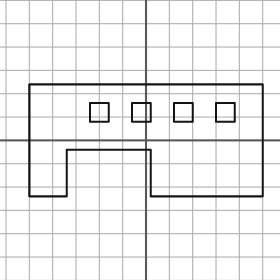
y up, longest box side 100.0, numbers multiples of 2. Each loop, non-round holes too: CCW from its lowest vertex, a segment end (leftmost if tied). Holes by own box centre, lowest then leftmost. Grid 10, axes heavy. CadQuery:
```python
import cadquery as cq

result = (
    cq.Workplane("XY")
    .moveTo(-50.0, -24.0)
    .lineTo(-34.0, -24.0)
    .lineTo(-34.0, -4.0)
    .lineTo(2.0, -4.0)
    .lineTo(2.0, -24.0)
    .lineTo(50.0, -24.0)
    .lineTo(50.0, 24.0)
    .lineTo(-50.0, 24.0)
    .close()
    .moveTo(-24.0, 8.0)
    .lineTo(-16.0, 8.0)
    .lineTo(-16.0, 16.0)
    .lineTo(-24.0, 16.0)
    .close()
    .moveTo(-6.0, 8.0)
    .lineTo(2.0, 8.0)
    .lineTo(2.0, 16.0)
    .lineTo(-6.0, 16.0)
    .close()
    .moveTo(12.0, 8.0)
    .lineTo(20.0, 8.0)
    .lineTo(20.0, 16.0)
    .lineTo(12.0, 16.0)
    .close()
    .moveTo(30.0, 8.0)
    .lineTo(38.0, 8.0)
    .lineTo(38.0, 16.0)
    .lineTo(30.0, 16.0)
    .close()
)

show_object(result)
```